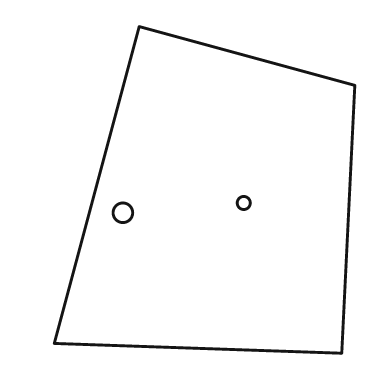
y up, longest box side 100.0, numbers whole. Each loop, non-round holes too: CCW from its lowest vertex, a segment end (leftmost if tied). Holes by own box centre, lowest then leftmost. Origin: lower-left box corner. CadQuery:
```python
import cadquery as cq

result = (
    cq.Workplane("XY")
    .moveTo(88.0, 0.0)
    .lineTo(92.0, 82.0)
    .lineTo(26.0, 100.0)
    .lineTo(0.0, 3.0)
    .close()
    .moveTo(21.0, 43.0)
    .circle(3.0)
    .moveTo(58.0, 46.0)
    .circle(2.0)
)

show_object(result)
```